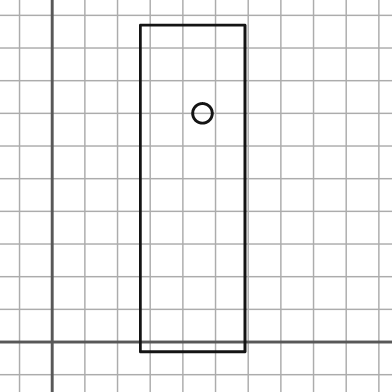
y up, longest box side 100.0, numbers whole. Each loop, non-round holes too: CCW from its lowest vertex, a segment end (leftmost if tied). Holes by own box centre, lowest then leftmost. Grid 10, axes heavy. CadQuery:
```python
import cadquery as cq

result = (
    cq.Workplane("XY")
    .moveTo(27.0, -3.0)
    .lineTo(59.0, -3.0)
    .lineTo(59.0, 97.0)
    .lineTo(27.0, 97.0)
    .close()
    .moveTo(46.0, 70.0)
    .circle(3.0)
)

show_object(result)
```